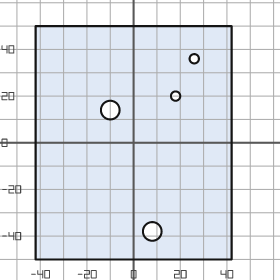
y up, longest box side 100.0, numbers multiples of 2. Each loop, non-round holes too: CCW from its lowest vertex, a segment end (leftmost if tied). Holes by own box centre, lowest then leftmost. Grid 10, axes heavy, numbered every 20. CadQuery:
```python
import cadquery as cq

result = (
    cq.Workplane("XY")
    .moveTo(-42.0, -50.0)
    .lineTo(42.0, -50.0)
    .lineTo(42.0, 50.0)
    .lineTo(-42.0, 50.0)
    .close()
    .moveTo(8.0, -38.0)
    .circle(4.0)
    .moveTo(-10.0, 14.0)
    .circle(4.0)
    .moveTo(18.0, 20.0)
    .circle(2.0)
    .moveTo(26.0, 36.0)
    .circle(2.0)
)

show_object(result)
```